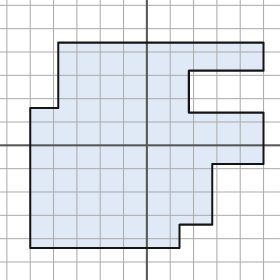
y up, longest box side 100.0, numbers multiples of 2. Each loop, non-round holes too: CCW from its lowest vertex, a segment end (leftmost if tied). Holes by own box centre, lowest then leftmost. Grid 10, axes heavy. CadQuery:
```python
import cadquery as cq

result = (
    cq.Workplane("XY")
    .moveTo(-50.0, -44.0)
    .lineTo(14.0, -44.0)
    .lineTo(14.0, -34.0)
    .lineTo(28.0, -34.0)
    .lineTo(28.0, -8.0)
    .lineTo(50.0, -8.0)
    .lineTo(50.0, 14.0)
    .lineTo(18.0, 14.0)
    .lineTo(18.0, 32.0)
    .lineTo(50.0, 32.0)
    .lineTo(50.0, 44.0)
    .lineTo(-38.0, 44.0)
    .lineTo(-38.0, 16.0)
    .lineTo(-50.0, 16.0)
    .close()
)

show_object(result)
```